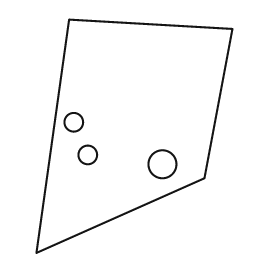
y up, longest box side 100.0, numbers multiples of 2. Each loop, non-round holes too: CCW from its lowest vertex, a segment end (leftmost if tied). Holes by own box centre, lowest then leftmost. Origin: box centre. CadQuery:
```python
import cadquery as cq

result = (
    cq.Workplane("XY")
    .moveTo(-42.0, -50.0)
    .lineTo(30.0, -18.0)
    .lineTo(42.0, 46.0)
    .lineTo(-28.0, 50.0)
    .close()
    .moveTo(12.0, -12.0)
    .circle(6.0)
    .moveTo(-20.0, -8.0)
    .circle(4.0)
    .moveTo(-26.0, 6.0)
    .circle(4.0)
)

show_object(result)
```